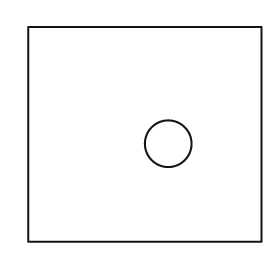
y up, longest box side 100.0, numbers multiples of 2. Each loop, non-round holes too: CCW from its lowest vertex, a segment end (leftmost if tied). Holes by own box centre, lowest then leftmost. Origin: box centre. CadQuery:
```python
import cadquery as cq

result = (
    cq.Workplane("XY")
    .moveTo(-50.0, -46.0)
    .lineTo(50.0, -46.0)
    .lineTo(50.0, 46.0)
    .lineTo(-50.0, 46.0)
    .close()
    .moveTo(10.0, -4.0)
    .circle(10.0)
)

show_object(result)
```